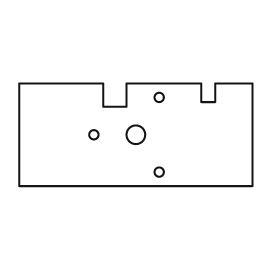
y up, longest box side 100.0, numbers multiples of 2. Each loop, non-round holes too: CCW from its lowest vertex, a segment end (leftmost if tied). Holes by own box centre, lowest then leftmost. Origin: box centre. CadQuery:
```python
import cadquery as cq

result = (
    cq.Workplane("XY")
    .moveTo(-50.0, -22.0)
    .lineTo(50.0, -22.0)
    .lineTo(50.0, 22.0)
    .lineTo(34.0, 22.0)
    .lineTo(34.0, 14.0)
    .lineTo(28.0, 14.0)
    .lineTo(28.0, 22.0)
    .lineTo(-4.0, 22.0)
    .lineTo(-4.0, 12.0)
    .lineTo(-14.0, 12.0)
    .lineTo(-14.0, 22.0)
    .lineTo(-50.0, 22.0)
    .close()
    .moveTo(10.0, -16.0)
    .circle(2.0)
    .moveTo(-18.0, 0.0)
    .circle(2.0)
    .moveTo(0.0, 0.0)
    .circle(4.0)
    .moveTo(10.0, 16.0)
    .circle(2.0)
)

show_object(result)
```